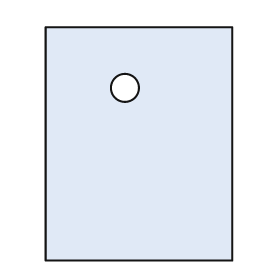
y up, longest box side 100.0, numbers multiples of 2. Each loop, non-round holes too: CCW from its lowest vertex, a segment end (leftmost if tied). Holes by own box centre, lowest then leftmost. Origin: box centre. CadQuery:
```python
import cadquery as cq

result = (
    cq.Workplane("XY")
    .moveTo(-40.0, -50.0)
    .lineTo(40.0, -50.0)
    .lineTo(40.0, 50.0)
    .lineTo(-40.0, 50.0)
    .close()
    .moveTo(-6.0, 24.0)
    .circle(6.0)
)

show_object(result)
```